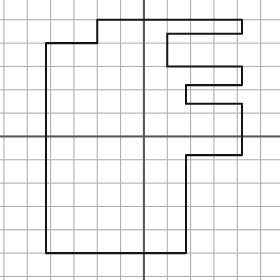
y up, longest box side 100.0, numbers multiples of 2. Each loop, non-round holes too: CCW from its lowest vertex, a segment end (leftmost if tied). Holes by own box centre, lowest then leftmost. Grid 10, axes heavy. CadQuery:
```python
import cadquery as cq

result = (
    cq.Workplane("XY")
    .moveTo(-42.0, -50.0)
    .lineTo(18.0, -50.0)
    .lineTo(18.0, -8.0)
    .lineTo(42.0, -8.0)
    .lineTo(42.0, 14.0)
    .lineTo(18.0, 14.0)
    .lineTo(18.0, 22.0)
    .lineTo(42.0, 22.0)
    .lineTo(42.0, 30.0)
    .lineTo(10.0, 30.0)
    .lineTo(10.0, 44.0)
    .lineTo(42.0, 44.0)
    .lineTo(42.0, 50.0)
    .lineTo(-20.0, 50.0)
    .lineTo(-20.0, 40.0)
    .lineTo(-42.0, 40.0)
    .close()
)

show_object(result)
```